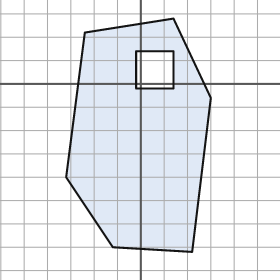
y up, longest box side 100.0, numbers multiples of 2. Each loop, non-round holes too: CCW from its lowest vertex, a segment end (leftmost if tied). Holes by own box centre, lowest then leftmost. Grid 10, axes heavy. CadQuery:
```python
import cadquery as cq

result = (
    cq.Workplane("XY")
    .moveTo(22.0, -72.0)
    .lineTo(30.0, -6.0)
    .lineTo(14.0, 28.0)
    .lineTo(-24.0, 22.0)
    .lineTo(-32.0, -40.0)
    .lineTo(-12.0, -70.0)
    .close()
    .moveTo(-2.0, -2.0)
    .lineTo(14.0, -2.0)
    .lineTo(14.0, 14.0)
    .lineTo(-2.0, 14.0)
    .close()
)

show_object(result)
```